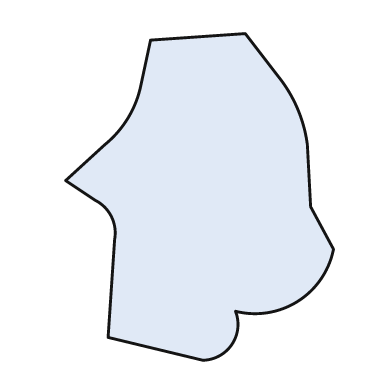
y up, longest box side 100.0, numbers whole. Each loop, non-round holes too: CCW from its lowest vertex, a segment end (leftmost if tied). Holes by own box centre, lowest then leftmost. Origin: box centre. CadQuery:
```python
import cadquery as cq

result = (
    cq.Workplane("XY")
    .moveTo(1.0, -50.0)
    .threePointArc((10.0, -45.0), (11.0, -35.0))
    .threePointArc((30.0, -32.0), (41.0, -16.0))
    .lineTo(34.0, -3.0)
    .lineTo(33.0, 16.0)
    .threePointArc((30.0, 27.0), (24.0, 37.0))
    .lineTo(14.0, 50.0)
    .lineTo(-15.0, 48.0)
    .lineTo(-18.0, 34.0)
    .threePointArc((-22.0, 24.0), (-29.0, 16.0))
    .lineTo(-41.0, 5.0)
    .lineTo(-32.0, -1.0)
    .threePointArc((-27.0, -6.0), (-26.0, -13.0))
    .lineTo(-28.0, -43.0)
    .close()
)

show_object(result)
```